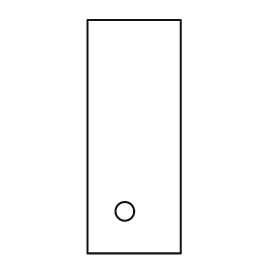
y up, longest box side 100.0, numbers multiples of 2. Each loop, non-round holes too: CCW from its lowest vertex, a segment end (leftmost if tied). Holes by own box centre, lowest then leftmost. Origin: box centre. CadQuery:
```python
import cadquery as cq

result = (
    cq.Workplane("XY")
    .moveTo(-20.0, -50.0)
    .lineTo(20.0, -50.0)
    .lineTo(20.0, 50.0)
    .lineTo(-20.0, 50.0)
    .close()
    .moveTo(-4.0, -32.0)
    .circle(4.0)
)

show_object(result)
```